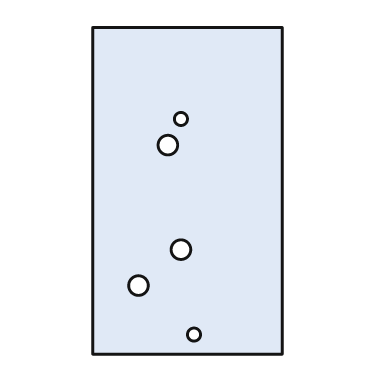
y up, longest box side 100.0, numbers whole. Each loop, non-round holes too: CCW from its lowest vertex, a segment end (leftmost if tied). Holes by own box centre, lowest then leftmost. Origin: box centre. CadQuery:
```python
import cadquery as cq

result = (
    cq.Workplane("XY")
    .moveTo(-29.0, -50.0)
    .lineTo(29.0, -50.0)
    .lineTo(29.0, 50.0)
    .lineTo(-29.0, 50.0)
    .close()
    .moveTo(2.0, -44.0)
    .circle(2.0)
    .moveTo(-15.0, -29.0)
    .circle(3.0)
    .moveTo(-2.0, -18.0)
    .circle(3.0)
    .moveTo(-6.0, 14.0)
    .circle(3.0)
    .moveTo(-2.0, 22.0)
    .circle(2.0)
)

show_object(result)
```